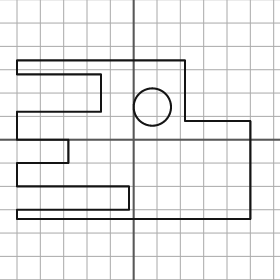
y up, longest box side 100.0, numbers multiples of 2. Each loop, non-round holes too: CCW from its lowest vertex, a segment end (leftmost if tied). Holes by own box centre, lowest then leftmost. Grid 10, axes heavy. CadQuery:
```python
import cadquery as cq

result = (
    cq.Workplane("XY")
    .moveTo(-50.0, -34.0)
    .lineTo(50.0, -34.0)
    .lineTo(50.0, 8.0)
    .lineTo(22.0, 8.0)
    .lineTo(22.0, 34.0)
    .lineTo(-50.0, 34.0)
    .lineTo(-50.0, 28.0)
    .lineTo(-14.0, 28.0)
    .lineTo(-14.0, 12.0)
    .lineTo(-50.0, 12.0)
    .lineTo(-50.0, 0.0)
    .lineTo(-28.0, 0.0)
    .lineTo(-28.0, -10.0)
    .lineTo(-50.0, -10.0)
    .lineTo(-50.0, -20.0)
    .lineTo(-2.0, -20.0)
    .lineTo(-2.0, -30.0)
    .lineTo(-50.0, -30.0)
    .close()
    .moveTo(8.0, 14.0)
    .circle(8.0)
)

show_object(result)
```